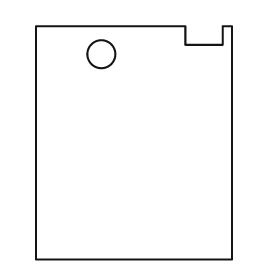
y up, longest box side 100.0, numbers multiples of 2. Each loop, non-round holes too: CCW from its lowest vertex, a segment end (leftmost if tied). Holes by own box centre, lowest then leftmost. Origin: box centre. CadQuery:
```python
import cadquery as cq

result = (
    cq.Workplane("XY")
    .moveTo(-42.0, -50.0)
    .lineTo(42.0, -50.0)
    .lineTo(42.0, 50.0)
    .lineTo(38.0, 50.0)
    .lineTo(38.0, 42.0)
    .lineTo(22.0, 42.0)
    .lineTo(22.0, 50.0)
    .lineTo(-42.0, 50.0)
    .close()
    .moveTo(-14.0, 38.0)
    .circle(6.0)
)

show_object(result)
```